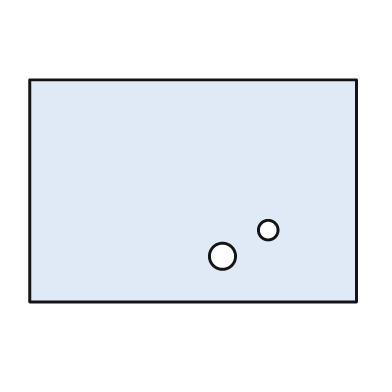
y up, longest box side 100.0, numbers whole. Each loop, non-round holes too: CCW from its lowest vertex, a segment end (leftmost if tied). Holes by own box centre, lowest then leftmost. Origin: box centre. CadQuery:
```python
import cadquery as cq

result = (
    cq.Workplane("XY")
    .moveTo(-50.0, -34.0)
    .lineTo(50.0, -34.0)
    .lineTo(50.0, 34.0)
    .lineTo(-50.0, 34.0)
    .close()
    .moveTo(9.0, -20.0)
    .circle(4.0)
    .moveTo(23.0, -12.0)
    .circle(3.0)
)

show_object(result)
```